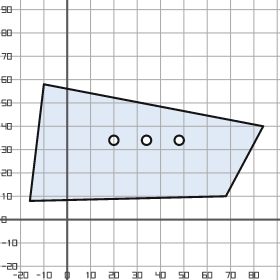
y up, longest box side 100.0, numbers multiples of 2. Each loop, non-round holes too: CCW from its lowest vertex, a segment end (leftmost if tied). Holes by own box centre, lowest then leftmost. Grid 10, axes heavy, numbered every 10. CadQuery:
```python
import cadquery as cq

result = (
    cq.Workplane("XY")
    .moveTo(-16.0, 8.0)
    .lineTo(68.0, 10.0)
    .lineTo(84.0, 40.0)
    .lineTo(-10.0, 58.0)
    .close()
    .moveTo(20.0, 34.0)
    .circle(2.0)
    .moveTo(34.0, 34.0)
    .circle(2.0)
    .moveTo(48.0, 34.0)
    .circle(2.0)
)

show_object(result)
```